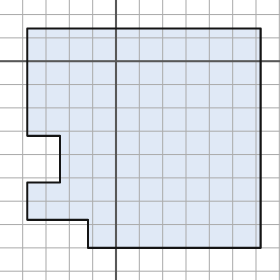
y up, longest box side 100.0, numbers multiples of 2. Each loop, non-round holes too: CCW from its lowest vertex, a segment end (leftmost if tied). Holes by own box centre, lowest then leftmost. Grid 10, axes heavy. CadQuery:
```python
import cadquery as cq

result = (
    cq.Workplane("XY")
    .moveTo(-12.0, -80.0)
    .lineTo(62.0, -80.0)
    .lineTo(62.0, 14.0)
    .lineTo(-38.0, 14.0)
    .lineTo(-38.0, -32.0)
    .lineTo(-24.0, -32.0)
    .lineTo(-24.0, -52.0)
    .lineTo(-38.0, -52.0)
    .lineTo(-38.0, -68.0)
    .lineTo(-12.0, -68.0)
    .close()
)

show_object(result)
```